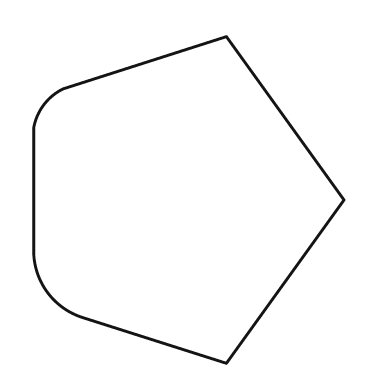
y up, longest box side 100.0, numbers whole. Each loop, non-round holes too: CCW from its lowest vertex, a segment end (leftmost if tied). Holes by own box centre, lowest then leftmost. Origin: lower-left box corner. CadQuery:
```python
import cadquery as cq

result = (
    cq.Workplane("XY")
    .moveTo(59.0, 0.0)
    .lineTo(95.0, 50.0)
    .lineTo(59.0, 100.0)
    .lineTo(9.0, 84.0)
    .threePointArc((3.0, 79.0), (0.0, 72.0))
    .lineTo(0.0, 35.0)
    .threePointArc((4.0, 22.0), (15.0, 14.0))
    .close()
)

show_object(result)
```